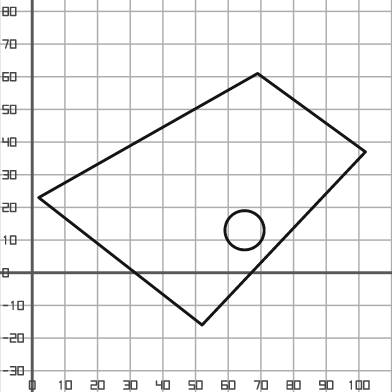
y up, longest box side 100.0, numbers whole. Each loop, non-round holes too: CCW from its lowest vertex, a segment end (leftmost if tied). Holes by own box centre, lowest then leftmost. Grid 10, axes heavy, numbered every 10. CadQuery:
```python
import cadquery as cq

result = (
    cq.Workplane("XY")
    .moveTo(52.0, -16.0)
    .lineTo(102.0, 37.0)
    .lineTo(69.0, 61.0)
    .lineTo(2.0, 23.0)
    .close()
    .moveTo(65.0, 13.0)
    .circle(6.0)
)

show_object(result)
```